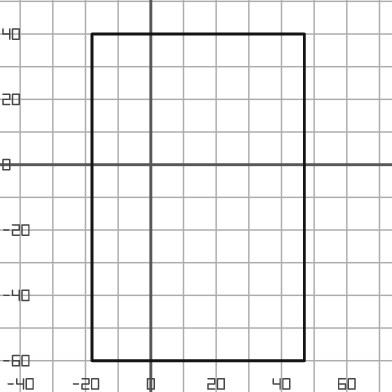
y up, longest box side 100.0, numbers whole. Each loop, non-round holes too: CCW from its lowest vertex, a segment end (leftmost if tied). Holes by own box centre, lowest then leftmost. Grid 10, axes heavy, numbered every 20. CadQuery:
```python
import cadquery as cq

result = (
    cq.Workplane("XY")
    .moveTo(-18.0, -60.0)
    .lineTo(47.0, -60.0)
    .lineTo(47.0, 40.0)
    .lineTo(-18.0, 40.0)
    .close()
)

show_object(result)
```